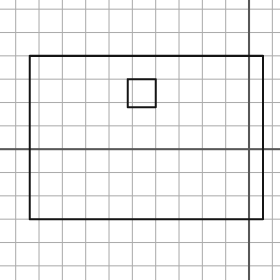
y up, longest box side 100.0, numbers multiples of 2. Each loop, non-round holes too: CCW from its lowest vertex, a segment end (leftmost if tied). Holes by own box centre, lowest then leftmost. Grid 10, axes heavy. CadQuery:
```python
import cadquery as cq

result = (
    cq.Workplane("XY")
    .moveTo(-94.0, -30.0)
    .lineTo(6.0, -30.0)
    .lineTo(6.0, 40.0)
    .lineTo(-94.0, 40.0)
    .close()
    .moveTo(-52.0, 18.0)
    .lineTo(-40.0, 18.0)
    .lineTo(-40.0, 30.0)
    .lineTo(-52.0, 30.0)
    .close()
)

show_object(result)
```